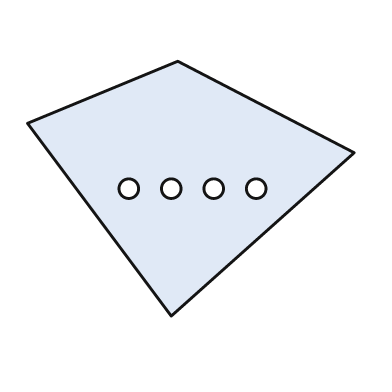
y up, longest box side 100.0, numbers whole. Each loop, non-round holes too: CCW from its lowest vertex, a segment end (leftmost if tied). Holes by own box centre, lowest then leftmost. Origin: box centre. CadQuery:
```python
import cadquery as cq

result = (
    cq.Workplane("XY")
    .moveTo(-6.0, -39.0)
    .lineTo(50.0, 11.0)
    .lineTo(-4.0, 39.0)
    .lineTo(-50.0, 20.0)
    .close()
    .moveTo(-19.0, 0.0)
    .circle(3.0)
    .moveTo(-6.0, 0.0)
    .circle(3.0)
    .moveTo(7.0, 0.0)
    .circle(3.0)
    .moveTo(20.0, 0.0)
    .circle(3.0)
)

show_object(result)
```